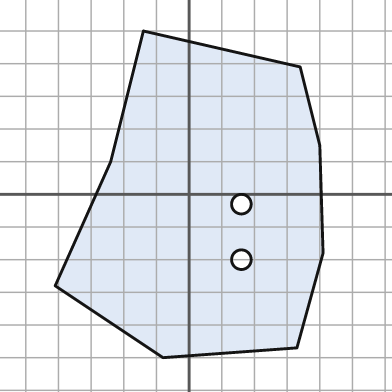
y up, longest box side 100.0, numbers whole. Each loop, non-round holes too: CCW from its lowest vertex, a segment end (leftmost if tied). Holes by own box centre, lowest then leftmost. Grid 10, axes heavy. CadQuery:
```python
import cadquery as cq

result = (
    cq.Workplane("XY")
    .moveTo(-8.0, -50.0)
    .lineTo(33.0, -47.0)
    .lineTo(41.0, -18.0)
    .lineTo(40.0, 15.0)
    .lineTo(34.0, 39.0)
    .lineTo(-14.0, 50.0)
    .lineTo(-24.0, 10.0)
    .lineTo(-41.0, -28.0)
    .close()
    .moveTo(16.0, -20.0)
    .circle(3.0)
    .moveTo(16.0, -3.0)
    .circle(3.0)
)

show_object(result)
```